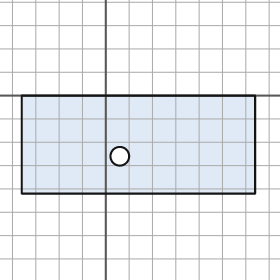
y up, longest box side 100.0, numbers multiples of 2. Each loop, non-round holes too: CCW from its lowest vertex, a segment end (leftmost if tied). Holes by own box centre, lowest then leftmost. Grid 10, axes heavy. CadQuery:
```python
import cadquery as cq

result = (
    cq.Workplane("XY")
    .moveTo(-36.0, -42.0)
    .lineTo(64.0, -42.0)
    .lineTo(64.0, 0.0)
    .lineTo(-36.0, 0.0)
    .close()
    .moveTo(6.0, -26.0)
    .circle(4.0)
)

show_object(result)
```